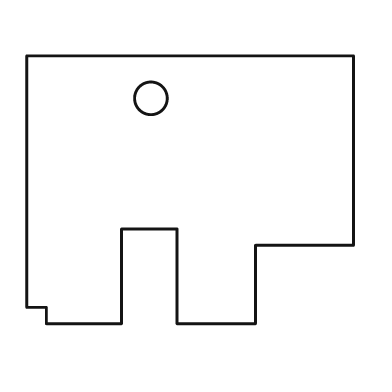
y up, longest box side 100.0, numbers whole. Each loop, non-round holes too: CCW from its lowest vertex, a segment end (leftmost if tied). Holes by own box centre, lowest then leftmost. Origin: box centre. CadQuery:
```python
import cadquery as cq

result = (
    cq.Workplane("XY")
    .moveTo(-44.0, -41.0)
    .lineTo(-21.0, -41.0)
    .lineTo(-21.0, -12.0)
    .lineTo(-4.0, -12.0)
    .lineTo(-4.0, -41.0)
    .lineTo(20.0, -41.0)
    .lineTo(20.0, -17.0)
    .lineTo(50.0, -17.0)
    .lineTo(50.0, 41.0)
    .lineTo(-50.0, 41.0)
    .lineTo(-50.0, -36.0)
    .lineTo(-44.0, -36.0)
    .close()
    .moveTo(-12.0, 28.0)
    .circle(5.0)
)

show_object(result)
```